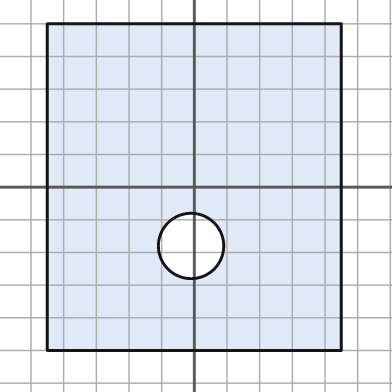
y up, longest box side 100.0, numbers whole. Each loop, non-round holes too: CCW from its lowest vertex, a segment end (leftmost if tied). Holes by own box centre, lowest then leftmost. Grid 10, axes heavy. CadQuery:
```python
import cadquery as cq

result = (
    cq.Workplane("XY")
    .moveTo(-45.0, -50.0)
    .lineTo(45.0, -50.0)
    .lineTo(45.0, 50.0)
    .lineTo(-45.0, 50.0)
    .close()
    .moveTo(-1.0, -18.0)
    .circle(10.0)
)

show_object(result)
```